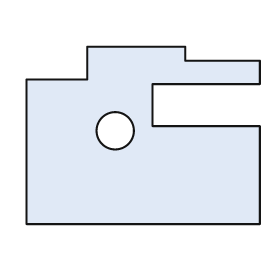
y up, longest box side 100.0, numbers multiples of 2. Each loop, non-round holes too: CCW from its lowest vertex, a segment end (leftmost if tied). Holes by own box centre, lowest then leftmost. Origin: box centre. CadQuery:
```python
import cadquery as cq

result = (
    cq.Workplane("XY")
    .moveTo(-50.0, -38.0)
    .lineTo(50.0, -38.0)
    .lineTo(50.0, 4.0)
    .lineTo(4.0, 4.0)
    .lineTo(4.0, 22.0)
    .lineTo(50.0, 22.0)
    .lineTo(50.0, 32.0)
    .lineTo(18.0, 32.0)
    .lineTo(18.0, 38.0)
    .lineTo(-24.0, 38.0)
    .lineTo(-24.0, 24.0)
    .lineTo(-50.0, 24.0)
    .close()
    .moveTo(-12.0, 2.0)
    .circle(8.0)
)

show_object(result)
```